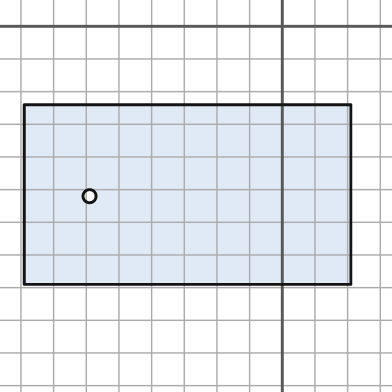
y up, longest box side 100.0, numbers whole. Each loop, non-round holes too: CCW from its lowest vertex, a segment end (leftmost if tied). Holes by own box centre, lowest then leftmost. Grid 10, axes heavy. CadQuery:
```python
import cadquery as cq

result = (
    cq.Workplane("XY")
    .moveTo(-79.0, -79.0)
    .lineTo(21.0, -79.0)
    .lineTo(21.0, -24.0)
    .lineTo(-79.0, -24.0)
    .close()
    .moveTo(-59.0, -52.0)
    .circle(2.0)
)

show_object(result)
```